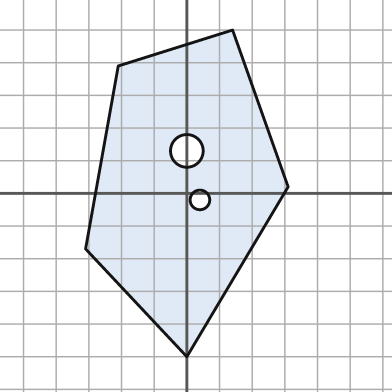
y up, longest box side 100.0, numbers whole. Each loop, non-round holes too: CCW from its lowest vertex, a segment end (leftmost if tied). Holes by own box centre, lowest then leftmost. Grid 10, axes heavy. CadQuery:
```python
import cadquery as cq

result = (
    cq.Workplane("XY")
    .moveTo(0.0, -50.0)
    .lineTo(31.0, 2.0)
    .lineTo(14.0, 50.0)
    .lineTo(-21.0, 39.0)
    .lineTo(-31.0, -17.0)
    .close()
    .moveTo(4.0, -2.0)
    .circle(3.0)
    .moveTo(0.0, 13.0)
    .circle(5.0)
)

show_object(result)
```